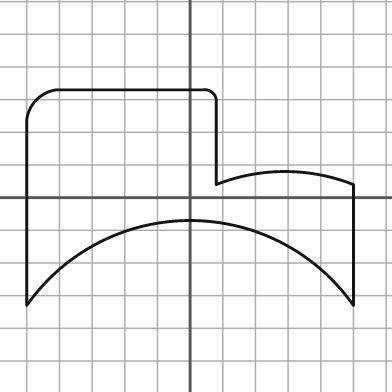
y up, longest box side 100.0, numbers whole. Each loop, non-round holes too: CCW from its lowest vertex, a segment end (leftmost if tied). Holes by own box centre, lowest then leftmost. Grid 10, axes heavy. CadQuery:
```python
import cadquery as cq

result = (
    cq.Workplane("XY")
    .moveTo(-50.0, -33.0)
    .threePointArc((0.0, -7.0), (50.0, -33.0))
    .lineTo(50.0, 4.0)
    .threePointArc((29.0, 8.0), (8.0, 4.0))
    .lineTo(8.0, 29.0)
    .threePointArc((7.0, 32.0), (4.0, 33.0))
    .lineTo(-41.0, 33.0)
    .threePointArc((-47.0, 30.0), (-50.0, 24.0))
    .close()
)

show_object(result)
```